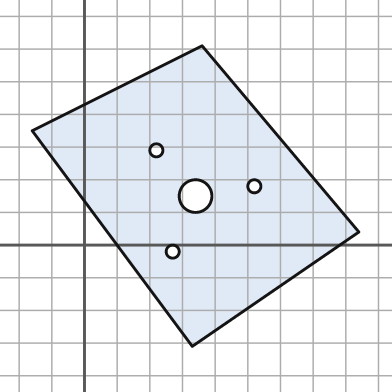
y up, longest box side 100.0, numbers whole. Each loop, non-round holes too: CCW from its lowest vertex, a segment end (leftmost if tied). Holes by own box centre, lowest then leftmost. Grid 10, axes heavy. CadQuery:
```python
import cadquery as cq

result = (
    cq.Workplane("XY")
    .moveTo(33.0, -31.0)
    .lineTo(84.0, 4.0)
    .lineTo(36.0, 61.0)
    .lineTo(-16.0, 35.0)
    .close()
    .moveTo(27.0, -2.0)
    .circle(2.0)
    .moveTo(34.0, 15.0)
    .circle(5.0)
    .moveTo(52.0, 18.0)
    .circle(2.0)
    .moveTo(22.0, 29.0)
    .circle(2.0)
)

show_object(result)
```